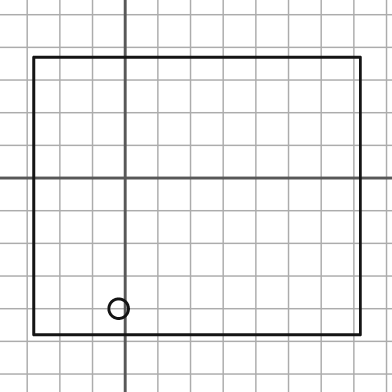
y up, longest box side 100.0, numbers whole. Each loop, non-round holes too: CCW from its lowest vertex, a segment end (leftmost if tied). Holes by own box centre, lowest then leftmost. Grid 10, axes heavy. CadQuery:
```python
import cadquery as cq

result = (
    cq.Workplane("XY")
    .moveTo(-28.0, -48.0)
    .lineTo(72.0, -48.0)
    .lineTo(72.0, 37.0)
    .lineTo(-28.0, 37.0)
    .close()
    .moveTo(-2.0, -40.0)
    .circle(3.0)
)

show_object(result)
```